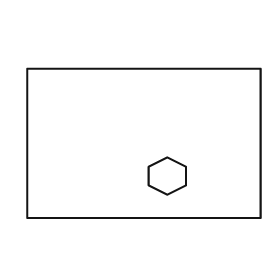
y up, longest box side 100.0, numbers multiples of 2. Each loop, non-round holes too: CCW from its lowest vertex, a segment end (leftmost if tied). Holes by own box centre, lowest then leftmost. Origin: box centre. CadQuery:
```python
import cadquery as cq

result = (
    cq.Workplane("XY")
    .moveTo(-50.0, -32.0)
    .lineTo(50.0, -32.0)
    .lineTo(50.0, 32.0)
    .lineTo(-50.0, 32.0)
    .close()
    .moveTo(10.0, -22.0)
    .lineTo(18.0, -18.0)
    .lineTo(18.0, -10.0)
    .lineTo(10.0, -6.0)
    .lineTo(2.0, -10.0)
    .lineTo(2.0, -18.0)
    .close()
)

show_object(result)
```